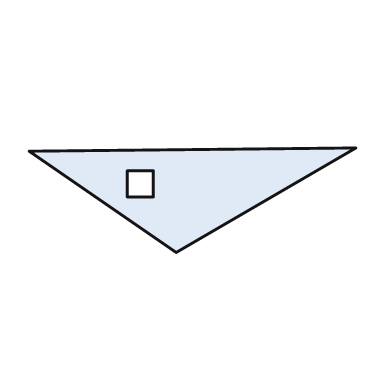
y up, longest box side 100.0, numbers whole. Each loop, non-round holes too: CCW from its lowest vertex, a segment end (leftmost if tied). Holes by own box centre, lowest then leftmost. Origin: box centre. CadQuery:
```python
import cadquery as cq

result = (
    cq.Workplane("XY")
    .moveTo(-5.0, -16.0)
    .lineTo(50.0, 16.0)
    .lineTo(-50.0, 15.0)
    .close()
    .moveTo(-20.0, 1.0)
    .lineTo(-12.0, 1.0)
    .lineTo(-12.0, 9.0)
    .lineTo(-20.0, 9.0)
    .close()
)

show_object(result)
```